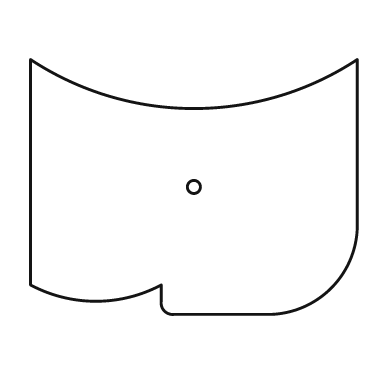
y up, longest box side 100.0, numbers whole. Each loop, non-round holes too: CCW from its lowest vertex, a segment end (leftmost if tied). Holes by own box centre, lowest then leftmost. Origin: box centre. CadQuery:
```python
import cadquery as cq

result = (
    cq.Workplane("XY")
    .moveTo(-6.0, -39.0)
    .lineTo(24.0, -39.0)
    .threePointArc((42.0, -31.0), (50.0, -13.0))
    .lineTo(50.0, 39.0)
    .threePointArc((0.0, 24.0), (-50.0, 39.0))
    .lineTo(-50.0, -30.0)
    .threePointArc((-30.0, -35.0), (-10.0, -30.0))
    .lineTo(-10.0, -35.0)
    .threePointArc((-9.0, -38.0), (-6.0, -39.0))
    .close()
    .moveTo(0.0, 0.0)
    .circle(2.0)
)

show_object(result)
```